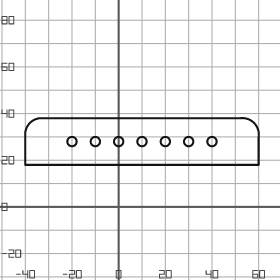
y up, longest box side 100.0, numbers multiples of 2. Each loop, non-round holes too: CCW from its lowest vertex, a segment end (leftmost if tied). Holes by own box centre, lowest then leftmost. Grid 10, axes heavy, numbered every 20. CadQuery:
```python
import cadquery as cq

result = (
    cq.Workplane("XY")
    .moveTo(-40.0, 18.0)
    .lineTo(60.0, 18.0)
    .lineTo(60.0, 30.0)
    .threePointArc((58.0, 36.0), (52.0, 38.0))
    .lineTo(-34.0, 38.0)
    .threePointArc((-38.0, 36.0), (-40.0, 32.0))
    .close()
    .moveTo(-20.0, 28.0)
    .circle(2.0)
    .moveTo(-10.0, 28.0)
    .circle(2.0)
    .moveTo(0.0, 28.0)
    .circle(2.0)
    .moveTo(10.0, 28.0)
    .circle(2.0)
    .moveTo(20.0, 28.0)
    .circle(2.0)
    .moveTo(30.0, 28.0)
    .circle(2.0)
    .moveTo(40.0, 28.0)
    .circle(2.0)
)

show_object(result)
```